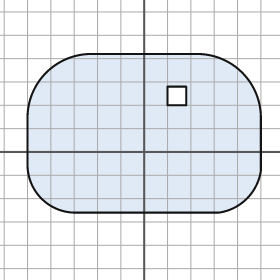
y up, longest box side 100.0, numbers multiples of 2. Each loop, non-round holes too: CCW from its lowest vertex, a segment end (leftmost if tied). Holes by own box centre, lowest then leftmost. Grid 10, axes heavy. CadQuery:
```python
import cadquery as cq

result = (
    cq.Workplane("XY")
    .moveTo(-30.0, -26.0)
    .lineTo(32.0, -26.0)
    .threePointArc((44.0, -20.0), (50.0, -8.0))
    .lineTo(50.0, 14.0)
    .threePointArc((42.0, 34.0), (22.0, 42.0))
    .lineTo(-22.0, 42.0)
    .threePointArc((-42.0, 34.0), (-50.0, 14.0))
    .lineTo(-50.0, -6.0)
    .threePointArc((-44.0, -20.0), (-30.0, -26.0))
    .close()
    .moveTo(10.0, 20.0)
    .lineTo(18.0, 20.0)
    .lineTo(18.0, 28.0)
    .lineTo(10.0, 28.0)
    .close()
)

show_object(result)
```